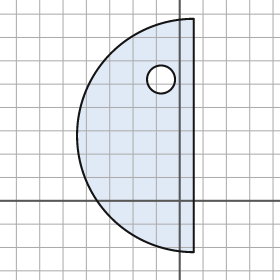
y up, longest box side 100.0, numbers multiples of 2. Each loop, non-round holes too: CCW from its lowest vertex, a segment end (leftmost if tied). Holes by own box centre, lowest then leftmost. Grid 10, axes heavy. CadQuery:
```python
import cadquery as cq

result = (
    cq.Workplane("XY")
    .moveTo(6.0, -22.0)
    .lineTo(6.0, 78.0)
    .threePointArc((-44.0, 28.0), (6.0, -22.0))
    .close()
    .moveTo(-8.0, 52.0)
    .circle(6.0)
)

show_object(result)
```